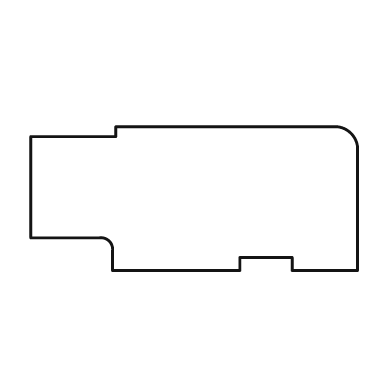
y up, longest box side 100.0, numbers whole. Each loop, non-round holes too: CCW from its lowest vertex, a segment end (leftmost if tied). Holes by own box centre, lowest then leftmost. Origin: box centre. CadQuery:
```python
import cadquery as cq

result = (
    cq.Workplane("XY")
    .moveTo(-25.0, -22.0)
    .lineTo(14.0, -22.0)
    .lineTo(14.0, -18.0)
    .lineTo(30.0, -18.0)
    .lineTo(30.0, -22.0)
    .lineTo(50.0, -22.0)
    .lineTo(50.0, 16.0)
    .threePointArc((48.0, 20.0), (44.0, 22.0))
    .lineTo(-24.0, 22.0)
    .lineTo(-24.0, 19.0)
    .lineTo(-50.0, 19.0)
    .lineTo(-50.0, -12.0)
    .lineTo(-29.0, -12.0)
    .threePointArc((-26.0, -13.0), (-25.0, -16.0))
    .close()
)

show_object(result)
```